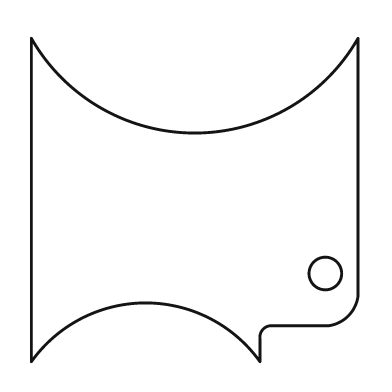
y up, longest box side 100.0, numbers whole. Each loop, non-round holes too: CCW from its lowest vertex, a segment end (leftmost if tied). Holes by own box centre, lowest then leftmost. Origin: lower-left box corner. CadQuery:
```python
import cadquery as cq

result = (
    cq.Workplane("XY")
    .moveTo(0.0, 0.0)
    .threePointArc((35.0, 18.0), (70.0, 0.0))
    .lineTo(70.0, 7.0)
    .threePointArc((71.0, 10.0), (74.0, 11.0))
    .lineTo(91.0, 11.0)
    .threePointArc((97.0, 14.0), (100.0, 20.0))
    .lineTo(100.0, 99.0)
    .threePointArc((50.0, 70.0), (0.0, 99.0))
    .close()
    .moveTo(90.0, 27.0)
    .circle(5.0)
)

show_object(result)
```